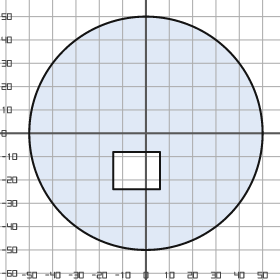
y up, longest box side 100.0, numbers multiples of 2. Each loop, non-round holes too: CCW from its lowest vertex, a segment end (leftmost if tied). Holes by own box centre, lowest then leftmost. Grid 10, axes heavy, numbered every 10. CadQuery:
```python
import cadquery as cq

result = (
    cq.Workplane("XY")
    .moveTo(0.0, 0.0)
    .circle(50.0)
    .moveTo(-14.0, -24.0)
    .lineTo(6.0, -24.0)
    .lineTo(6.0, -8.0)
    .lineTo(-14.0, -8.0)
    .close()
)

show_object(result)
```